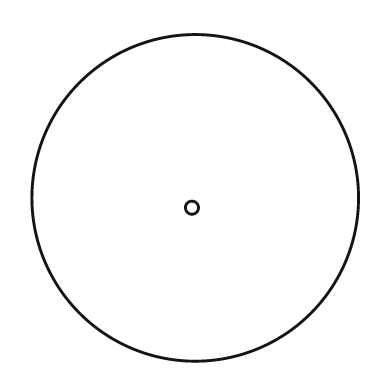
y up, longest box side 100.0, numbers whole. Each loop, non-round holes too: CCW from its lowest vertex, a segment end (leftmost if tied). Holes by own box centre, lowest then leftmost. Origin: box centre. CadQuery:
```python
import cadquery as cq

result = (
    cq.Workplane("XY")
    .moveTo(0.0, 0.0)
    .circle(50.0)
    .moveTo(-1.0, -3.0)
    .circle(2.0)
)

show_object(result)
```